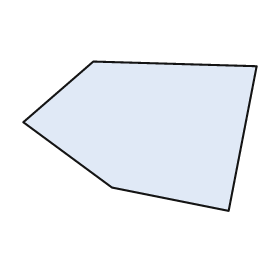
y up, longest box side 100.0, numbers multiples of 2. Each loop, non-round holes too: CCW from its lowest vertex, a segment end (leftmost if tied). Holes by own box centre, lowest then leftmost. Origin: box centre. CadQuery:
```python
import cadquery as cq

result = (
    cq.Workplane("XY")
    .moveTo(38.0, -32.0)
    .lineTo(50.0, 30.0)
    .lineTo(-20.0, 32.0)
    .lineTo(-50.0, 6.0)
    .lineTo(-12.0, -22.0)
    .close()
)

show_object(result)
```